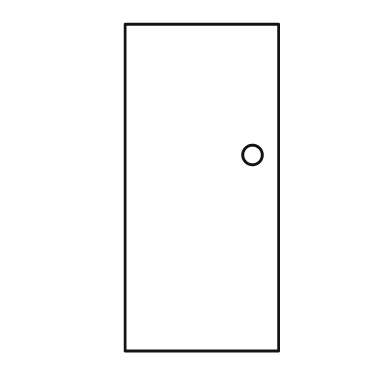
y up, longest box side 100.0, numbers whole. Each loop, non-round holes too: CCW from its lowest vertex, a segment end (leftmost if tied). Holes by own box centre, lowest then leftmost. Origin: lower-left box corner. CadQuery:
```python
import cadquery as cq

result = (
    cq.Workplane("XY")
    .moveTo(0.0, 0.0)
    .lineTo(47.0, 0.0)
    .lineTo(47.0, 100.0)
    .lineTo(0.0, 100.0)
    .close()
    .moveTo(39.0, 60.0)
    .circle(3.0)
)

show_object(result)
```